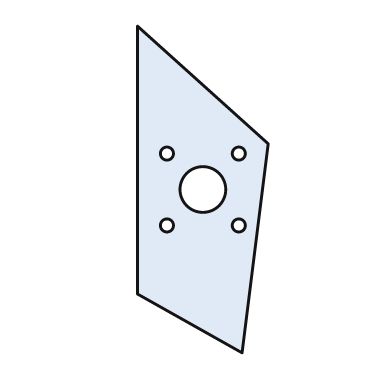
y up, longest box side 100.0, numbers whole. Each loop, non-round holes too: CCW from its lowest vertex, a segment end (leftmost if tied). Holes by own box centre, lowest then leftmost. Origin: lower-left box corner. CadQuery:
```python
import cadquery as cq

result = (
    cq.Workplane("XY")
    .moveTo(32.0, 0.0)
    .lineTo(40.0, 64.0)
    .lineTo(0.0, 100.0)
    .lineTo(0.0, 18.0)
    .close()
    .moveTo(9.0, 39.0)
    .circle(2.0)
    .moveTo(31.0, 39.0)
    .circle(2.0)
    .moveTo(20.0, 50.0)
    .circle(7.0)
    .moveTo(9.0, 61.0)
    .circle(2.0)
    .moveTo(31.0, 61.0)
    .circle(2.0)
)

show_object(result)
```